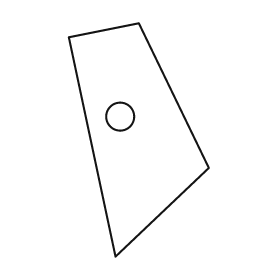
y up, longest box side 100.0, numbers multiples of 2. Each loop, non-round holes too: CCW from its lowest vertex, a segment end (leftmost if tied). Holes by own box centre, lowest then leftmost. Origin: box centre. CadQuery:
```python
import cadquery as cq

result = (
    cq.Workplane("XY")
    .moveTo(-10.0, -50.0)
    .lineTo(30.0, -12.0)
    .lineTo(0.0, 50.0)
    .lineTo(-30.0, 44.0)
    .close()
    .moveTo(-8.0, 10.0)
    .circle(6.0)
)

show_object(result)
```